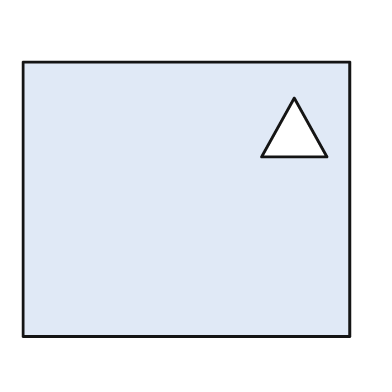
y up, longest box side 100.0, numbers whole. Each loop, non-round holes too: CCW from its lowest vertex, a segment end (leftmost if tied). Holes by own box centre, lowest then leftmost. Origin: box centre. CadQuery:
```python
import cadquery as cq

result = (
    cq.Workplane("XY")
    .moveTo(-50.0, -42.0)
    .lineTo(50.0, -42.0)
    .lineTo(50.0, 42.0)
    .lineTo(-50.0, 42.0)
    .close()
    .moveTo(23.0, 13.0)
    .lineTo(43.0, 13.0)
    .lineTo(33.0, 31.0)
    .close()
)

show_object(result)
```